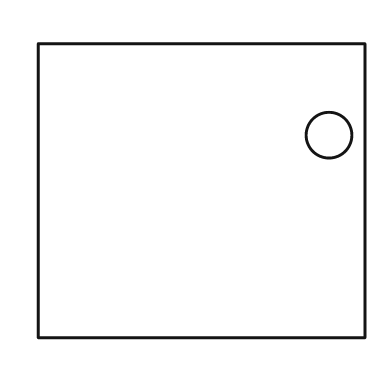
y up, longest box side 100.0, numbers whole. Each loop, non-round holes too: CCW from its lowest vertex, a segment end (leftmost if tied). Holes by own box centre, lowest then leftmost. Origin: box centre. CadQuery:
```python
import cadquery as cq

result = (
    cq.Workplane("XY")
    .moveTo(-50.0, -45.0)
    .lineTo(50.0, -45.0)
    .lineTo(50.0, 45.0)
    .lineTo(-50.0, 45.0)
    .close()
    .moveTo(39.0, 17.0)
    .circle(7.0)
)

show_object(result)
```